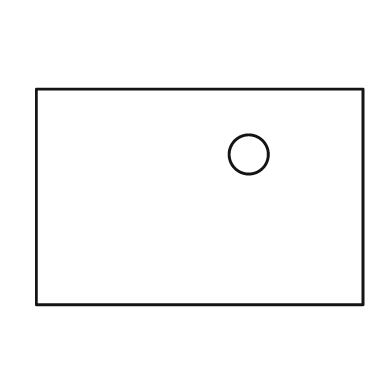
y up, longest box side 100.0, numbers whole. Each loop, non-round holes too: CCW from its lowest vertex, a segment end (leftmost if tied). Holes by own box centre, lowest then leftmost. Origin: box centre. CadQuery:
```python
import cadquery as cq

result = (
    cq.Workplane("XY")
    .moveTo(-50.0, -33.0)
    .lineTo(50.0, -33.0)
    .lineTo(50.0, 33.0)
    .lineTo(-50.0, 33.0)
    .close()
    .moveTo(15.0, 13.0)
    .circle(6.0)
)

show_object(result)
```